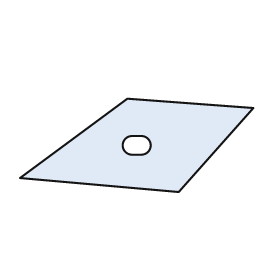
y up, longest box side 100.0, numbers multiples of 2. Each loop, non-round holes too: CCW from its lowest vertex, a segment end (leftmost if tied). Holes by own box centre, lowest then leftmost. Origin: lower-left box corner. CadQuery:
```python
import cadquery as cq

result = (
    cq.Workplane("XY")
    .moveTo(68.0, 0.0)
    .lineTo(100.0, 36.0)
    .lineTo(46.0, 40.0)
    .lineTo(0.0, 6.0)
    .close()
    .moveTo(48.0, 16.0)
    .lineTo(52.0, 16.0)
    .threePointArc((56.0, 20.0), (52.0, 24.0))
    .lineTo(48.0, 24.0)
    .threePointArc((44.0, 20.0), (48.0, 16.0))
    .close()
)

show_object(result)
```